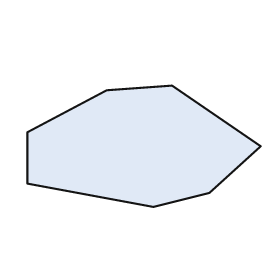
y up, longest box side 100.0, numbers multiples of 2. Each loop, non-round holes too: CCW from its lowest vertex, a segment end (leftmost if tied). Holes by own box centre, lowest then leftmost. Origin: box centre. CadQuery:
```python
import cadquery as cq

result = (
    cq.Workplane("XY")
    .moveTo(4.0, -26.0)
    .lineTo(28.0, -20.0)
    .lineTo(50.0, 0.0)
    .lineTo(12.0, 26.0)
    .lineTo(-16.0, 24.0)
    .lineTo(-50.0, 6.0)
    .lineTo(-50.0, -16.0)
    .close()
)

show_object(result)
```